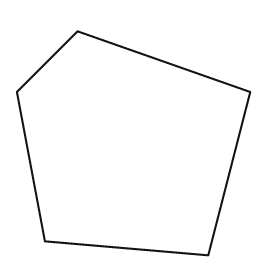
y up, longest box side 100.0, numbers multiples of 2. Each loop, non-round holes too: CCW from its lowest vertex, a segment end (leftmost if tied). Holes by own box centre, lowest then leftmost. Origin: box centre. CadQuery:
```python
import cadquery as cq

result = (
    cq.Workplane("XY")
    .moveTo(32.0, -48.0)
    .lineTo(50.0, 22.0)
    .lineTo(-24.0, 48.0)
    .lineTo(-50.0, 22.0)
    .lineTo(-38.0, -42.0)
    .close()
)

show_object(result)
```